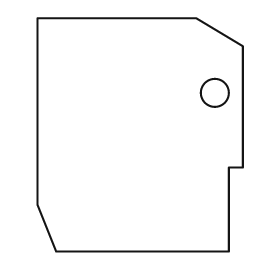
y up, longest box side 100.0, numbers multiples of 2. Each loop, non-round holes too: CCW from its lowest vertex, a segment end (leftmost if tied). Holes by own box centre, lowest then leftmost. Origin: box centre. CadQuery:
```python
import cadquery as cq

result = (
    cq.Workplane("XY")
    .moveTo(-36.0, -50.0)
    .lineTo(38.0, -50.0)
    .lineTo(38.0, -14.0)
    .lineTo(44.0, -14.0)
    .lineTo(44.0, 38.0)
    .lineTo(24.0, 50.0)
    .lineTo(-44.0, 50.0)
    .lineTo(-44.0, -30.0)
    .close()
    .moveTo(32.0, 18.0)
    .circle(6.0)
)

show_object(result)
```